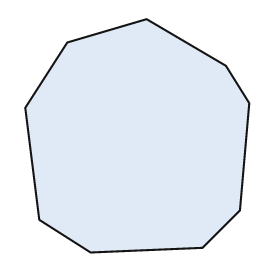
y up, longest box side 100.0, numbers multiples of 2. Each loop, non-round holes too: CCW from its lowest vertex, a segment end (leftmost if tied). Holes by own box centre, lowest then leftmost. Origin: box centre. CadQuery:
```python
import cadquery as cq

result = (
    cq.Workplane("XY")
    .moveTo(-20.0, -50.0)
    .lineTo(28.0, -48.0)
    .lineTo(44.0, -32.0)
    .lineTo(48.0, 14.0)
    .lineTo(38.0, 30.0)
    .lineTo(4.0, 50.0)
    .lineTo(-30.0, 40.0)
    .lineTo(-48.0, 12.0)
    .lineTo(-42.0, -36.0)
    .close()
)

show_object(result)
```